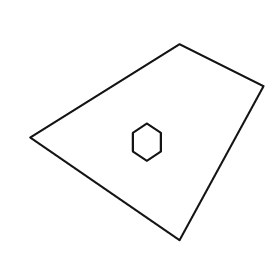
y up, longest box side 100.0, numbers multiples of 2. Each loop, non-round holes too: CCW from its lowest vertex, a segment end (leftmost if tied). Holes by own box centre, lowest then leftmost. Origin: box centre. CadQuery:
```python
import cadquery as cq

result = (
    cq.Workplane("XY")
    .moveTo(14.0, -42.0)
    .lineTo(50.0, 24.0)
    .lineTo(14.0, 42.0)
    .lineTo(-50.0, 2.0)
    .close()
    .moveTo(0.0, -8.0)
    .lineTo(6.0, -4.0)
    .lineTo(6.0, 4.0)
    .lineTo(0.0, 8.0)
    .lineTo(-6.0, 4.0)
    .lineTo(-6.0, -4.0)
    .close()
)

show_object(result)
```